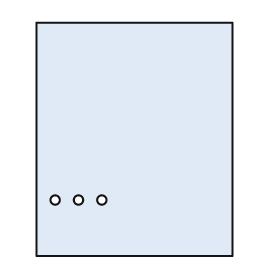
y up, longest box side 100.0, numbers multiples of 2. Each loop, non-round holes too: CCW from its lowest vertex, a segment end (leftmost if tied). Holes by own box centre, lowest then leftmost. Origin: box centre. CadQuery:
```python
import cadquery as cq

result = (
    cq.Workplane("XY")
    .moveTo(-42.0, -50.0)
    .lineTo(42.0, -50.0)
    .lineTo(42.0, 50.0)
    .lineTo(-42.0, 50.0)
    .close()
    .moveTo(-34.0, -26.0)
    .circle(2.0)
    .moveTo(-24.0, -26.0)
    .circle(2.0)
    .moveTo(-14.0, -26.0)
    .circle(2.0)
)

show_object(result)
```